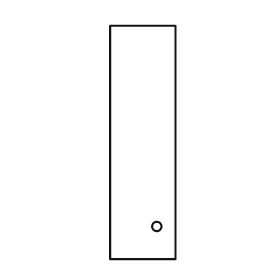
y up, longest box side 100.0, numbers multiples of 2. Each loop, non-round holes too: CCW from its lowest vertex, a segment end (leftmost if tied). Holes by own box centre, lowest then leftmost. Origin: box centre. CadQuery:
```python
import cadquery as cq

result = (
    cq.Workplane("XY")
    .moveTo(-14.0, -50.0)
    .lineTo(14.0, -50.0)
    .lineTo(14.0, 50.0)
    .lineTo(-14.0, 50.0)
    .close()
    .moveTo(6.0, -36.0)
    .circle(2.0)
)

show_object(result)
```